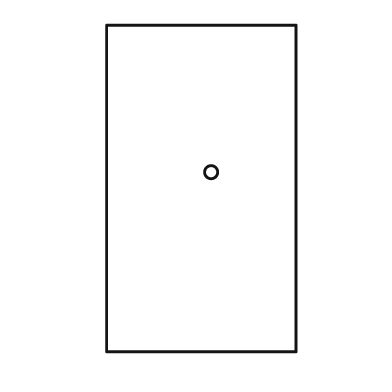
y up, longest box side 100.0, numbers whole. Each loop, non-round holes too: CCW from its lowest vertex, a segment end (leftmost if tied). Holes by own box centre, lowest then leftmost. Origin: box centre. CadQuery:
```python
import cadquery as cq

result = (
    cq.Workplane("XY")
    .moveTo(-29.0, -50.0)
    .lineTo(29.0, -50.0)
    .lineTo(29.0, 50.0)
    .lineTo(-29.0, 50.0)
    .close()
    .moveTo(3.0, 5.0)
    .circle(2.0)
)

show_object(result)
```